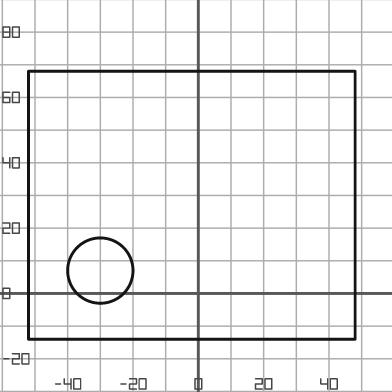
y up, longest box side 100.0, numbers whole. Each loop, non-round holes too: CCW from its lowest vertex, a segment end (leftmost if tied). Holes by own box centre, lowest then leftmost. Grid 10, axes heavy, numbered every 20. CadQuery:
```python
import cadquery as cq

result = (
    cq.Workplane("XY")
    .moveTo(-52.0, -14.0)
    .lineTo(48.0, -14.0)
    .lineTo(48.0, 68.0)
    .lineTo(-52.0, 68.0)
    .close()
    .moveTo(-30.0, 7.0)
    .circle(10.0)
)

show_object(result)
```